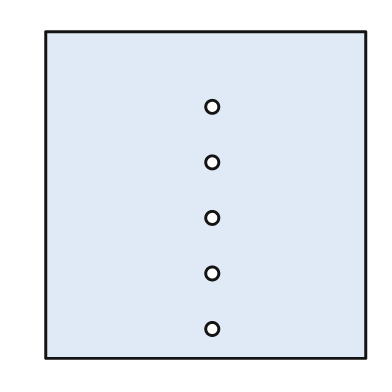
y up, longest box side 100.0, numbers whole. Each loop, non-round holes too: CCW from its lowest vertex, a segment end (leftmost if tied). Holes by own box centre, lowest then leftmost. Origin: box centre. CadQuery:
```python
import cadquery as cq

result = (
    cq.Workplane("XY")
    .moveTo(-49.0, -50.0)
    .lineTo(49.0, -50.0)
    .lineTo(49.0, 50.0)
    .lineTo(-49.0, 50.0)
    .close()
    .moveTo(2.0, -41.0)
    .circle(2.0)
    .moveTo(2.0, -24.0)
    .circle(2.0)
    .moveTo(2.0, -7.0)
    .circle(2.0)
    .moveTo(2.0, 10.0)
    .circle(2.0)
    .moveTo(2.0, 27.0)
    .circle(2.0)
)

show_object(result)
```